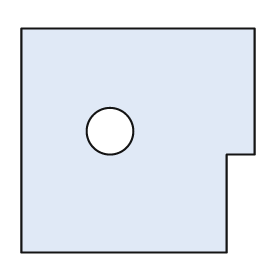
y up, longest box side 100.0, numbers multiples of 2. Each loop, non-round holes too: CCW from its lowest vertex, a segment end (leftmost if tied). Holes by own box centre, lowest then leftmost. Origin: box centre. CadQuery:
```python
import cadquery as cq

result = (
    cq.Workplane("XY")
    .moveTo(-50.0, -48.0)
    .lineTo(38.0, -48.0)
    .lineTo(38.0, -6.0)
    .lineTo(50.0, -6.0)
    .lineTo(50.0, 48.0)
    .lineTo(-50.0, 48.0)
    .close()
    .moveTo(-12.0, 4.0)
    .circle(10.0)
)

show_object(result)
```